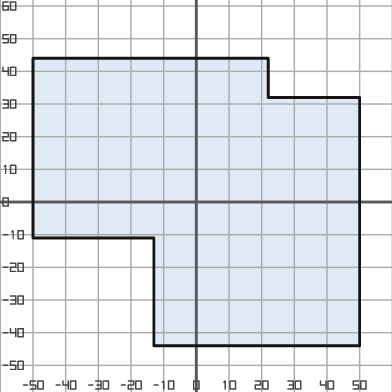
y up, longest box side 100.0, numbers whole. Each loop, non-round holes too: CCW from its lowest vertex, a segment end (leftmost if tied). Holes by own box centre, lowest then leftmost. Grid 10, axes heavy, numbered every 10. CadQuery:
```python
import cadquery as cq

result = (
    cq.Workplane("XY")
    .moveTo(-13.0, -44.0)
    .lineTo(50.0, -44.0)
    .lineTo(50.0, 32.0)
    .lineTo(22.0, 32.0)
    .lineTo(22.0, 44.0)
    .lineTo(-50.0, 44.0)
    .lineTo(-50.0, -11.0)
    .lineTo(-13.0, -11.0)
    .close()
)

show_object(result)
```